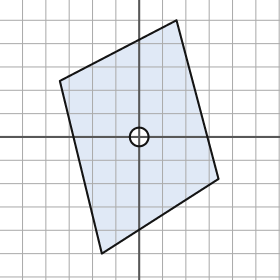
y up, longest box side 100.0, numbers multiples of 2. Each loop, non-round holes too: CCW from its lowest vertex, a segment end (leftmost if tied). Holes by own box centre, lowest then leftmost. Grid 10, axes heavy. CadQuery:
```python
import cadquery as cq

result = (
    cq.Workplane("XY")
    .moveTo(-16.0, -50.0)
    .lineTo(34.0, -18.0)
    .lineTo(16.0, 50.0)
    .lineTo(-34.0, 24.0)
    .close()
    .moveTo(0.0, 0.0)
    .circle(4.0)
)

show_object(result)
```